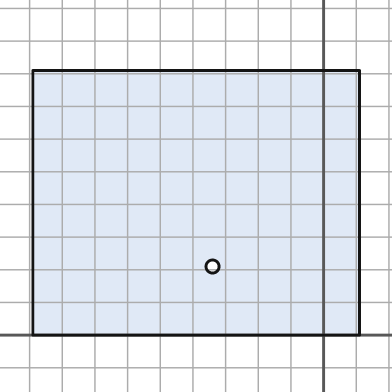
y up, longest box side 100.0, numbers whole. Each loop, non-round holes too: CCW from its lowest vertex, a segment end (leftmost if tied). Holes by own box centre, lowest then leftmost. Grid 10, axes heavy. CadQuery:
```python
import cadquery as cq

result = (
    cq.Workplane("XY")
    .moveTo(-89.0, 0.0)
    .lineTo(11.0, 0.0)
    .lineTo(11.0, 81.0)
    .lineTo(-89.0, 81.0)
    .close()
    .moveTo(-34.0, 21.0)
    .circle(2.0)
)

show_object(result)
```